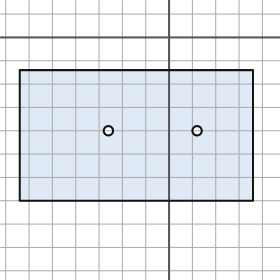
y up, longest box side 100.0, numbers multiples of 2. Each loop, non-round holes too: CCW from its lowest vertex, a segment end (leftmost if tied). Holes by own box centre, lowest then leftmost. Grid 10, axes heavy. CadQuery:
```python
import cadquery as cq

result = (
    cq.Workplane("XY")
    .moveTo(-64.0, -70.0)
    .lineTo(36.0, -70.0)
    .lineTo(36.0, -14.0)
    .lineTo(-64.0, -14.0)
    .close()
    .moveTo(-26.0, -40.0)
    .circle(2.0)
    .moveTo(12.0, -40.0)
    .circle(2.0)
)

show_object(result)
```